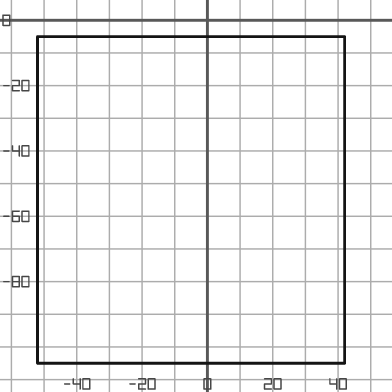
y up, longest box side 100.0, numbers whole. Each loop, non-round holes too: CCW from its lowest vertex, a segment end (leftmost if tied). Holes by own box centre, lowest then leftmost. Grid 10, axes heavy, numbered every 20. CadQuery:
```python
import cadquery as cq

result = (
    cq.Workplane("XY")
    .moveTo(-52.0, -105.0)
    .lineTo(42.0, -105.0)
    .lineTo(42.0, -5.0)
    .lineTo(-52.0, -5.0)
    .close()
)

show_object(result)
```